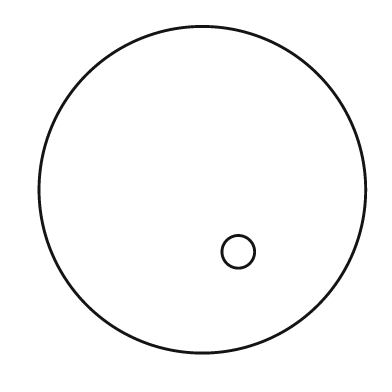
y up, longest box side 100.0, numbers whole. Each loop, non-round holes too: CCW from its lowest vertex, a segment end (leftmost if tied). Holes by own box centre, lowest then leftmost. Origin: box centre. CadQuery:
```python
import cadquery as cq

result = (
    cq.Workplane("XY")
    .moveTo(0.0, 0.0)
    .circle(50.0)
    .moveTo(11.0, -19.0)
    .circle(5.0)
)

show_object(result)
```